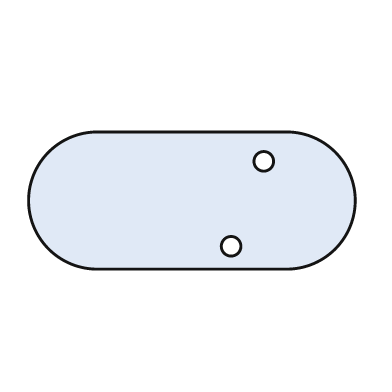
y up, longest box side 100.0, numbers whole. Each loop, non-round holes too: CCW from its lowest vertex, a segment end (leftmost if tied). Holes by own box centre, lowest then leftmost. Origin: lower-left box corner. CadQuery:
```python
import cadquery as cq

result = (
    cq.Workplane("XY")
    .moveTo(21.0, 0.0)
    .lineTo(79.0, 0.0)
    .threePointArc((100.0, 21.0), (79.0, 42.0))
    .lineTo(21.0, 42.0)
    .threePointArc((0.0, 21.0), (21.0, 0.0))
    .close()
    .moveTo(62.0, 7.0)
    .circle(3.0)
    .moveTo(72.0, 33.0)
    .circle(3.0)
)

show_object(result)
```